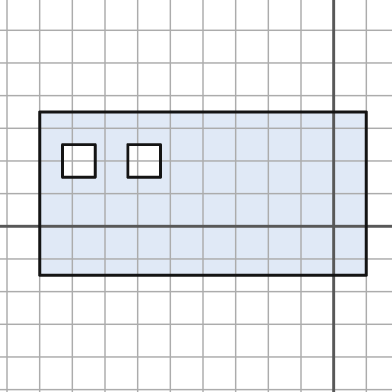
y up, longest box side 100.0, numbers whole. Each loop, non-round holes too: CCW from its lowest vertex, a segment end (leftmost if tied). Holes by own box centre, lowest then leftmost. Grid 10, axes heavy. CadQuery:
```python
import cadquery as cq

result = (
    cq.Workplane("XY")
    .moveTo(-90.0, -15.0)
    .lineTo(10.0, -15.0)
    .lineTo(10.0, 35.0)
    .lineTo(-90.0, 35.0)
    .close()
    .moveTo(-83.0, 15.0)
    .lineTo(-73.0, 15.0)
    .lineTo(-73.0, 25.0)
    .lineTo(-83.0, 25.0)
    .close()
    .moveTo(-63.0, 15.0)
    .lineTo(-53.0, 15.0)
    .lineTo(-53.0, 25.0)
    .lineTo(-63.0, 25.0)
    .close()
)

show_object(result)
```